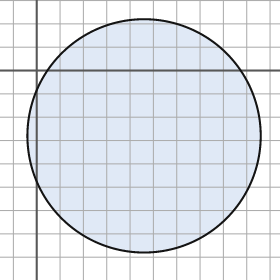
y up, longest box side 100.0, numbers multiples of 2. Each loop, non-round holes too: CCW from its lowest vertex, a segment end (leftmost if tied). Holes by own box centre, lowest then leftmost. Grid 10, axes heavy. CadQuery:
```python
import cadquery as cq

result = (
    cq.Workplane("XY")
    .moveTo(46.0, -28.0)
    .circle(50.0)
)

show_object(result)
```